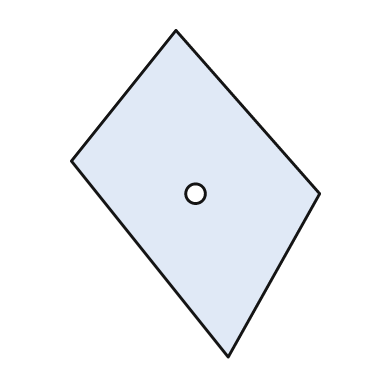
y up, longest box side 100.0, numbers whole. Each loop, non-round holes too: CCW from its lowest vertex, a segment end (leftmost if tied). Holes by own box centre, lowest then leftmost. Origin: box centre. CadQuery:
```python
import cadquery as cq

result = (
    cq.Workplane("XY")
    .moveTo(10.0, -50.0)
    .lineTo(38.0, 0.0)
    .lineTo(-6.0, 50.0)
    .lineTo(-38.0, 10.0)
    .close()
    .moveTo(0.0, 0.0)
    .circle(3.0)
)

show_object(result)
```